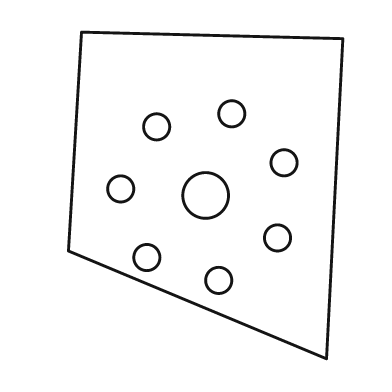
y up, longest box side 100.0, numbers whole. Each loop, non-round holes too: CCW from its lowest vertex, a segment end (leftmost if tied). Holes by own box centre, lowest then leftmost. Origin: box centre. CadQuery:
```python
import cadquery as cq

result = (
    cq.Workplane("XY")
    .moveTo(37.0, -50.0)
    .lineTo(42.0, 48.0)
    .lineTo(-38.0, 50.0)
    .lineTo(-42.0, -17.0)
    .close()
    .moveTo(4.0, -26.0)
    .circle(4.0)
    .moveTo(-18.0, -19.0)
    .circle(4.0)
    .moveTo(22.0, -13.0)
    .circle(4.0)
    .moveTo(0.0, 0.0)
    .circle(7.0)
    .moveTo(-26.0, 2.0)
    .circle(4.0)
    .moveTo(24.0, 10.0)
    .circle(4.0)
    .moveTo(-15.0, 21.0)
    .circle(4.0)
    .moveTo(8.0, 25.0)
    .circle(4.0)
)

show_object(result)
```